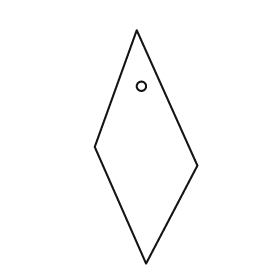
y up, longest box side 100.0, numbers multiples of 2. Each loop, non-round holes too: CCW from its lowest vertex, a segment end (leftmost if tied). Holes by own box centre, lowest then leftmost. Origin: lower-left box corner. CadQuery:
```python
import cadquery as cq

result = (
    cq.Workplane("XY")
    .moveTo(22.0, 0.0)
    .lineTo(44.0, 42.0)
    .lineTo(18.0, 100.0)
    .lineTo(0.0, 50.0)
    .close()
    .moveTo(20.0, 76.0)
    .circle(2.0)
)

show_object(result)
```